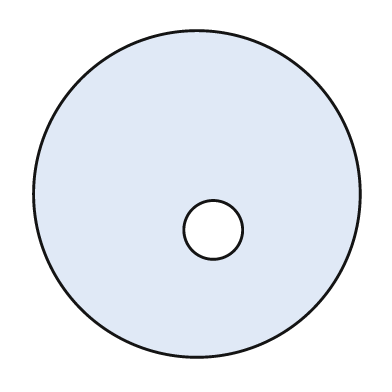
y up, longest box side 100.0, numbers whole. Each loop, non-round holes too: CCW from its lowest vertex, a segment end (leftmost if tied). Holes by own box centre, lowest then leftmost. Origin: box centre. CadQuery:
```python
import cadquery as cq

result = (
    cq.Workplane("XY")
    .moveTo(0.0, 0.0)
    .circle(50.0)
    .moveTo(5.0, -11.0)
    .circle(9.0)
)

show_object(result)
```